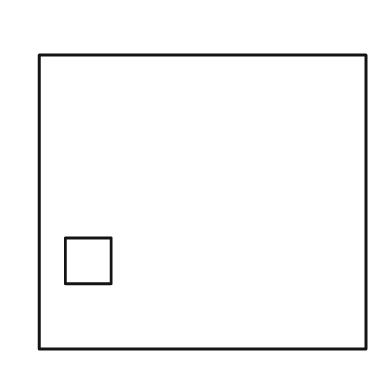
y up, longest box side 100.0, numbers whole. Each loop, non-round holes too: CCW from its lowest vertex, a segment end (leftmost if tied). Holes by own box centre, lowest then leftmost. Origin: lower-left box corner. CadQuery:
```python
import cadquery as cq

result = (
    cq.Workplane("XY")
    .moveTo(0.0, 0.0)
    .lineTo(100.0, 0.0)
    .lineTo(100.0, 90.0)
    .lineTo(0.0, 90.0)
    .close()
    .moveTo(8.0, 20.0)
    .lineTo(22.0, 20.0)
    .lineTo(22.0, 34.0)
    .lineTo(8.0, 34.0)
    .close()
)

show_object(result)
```